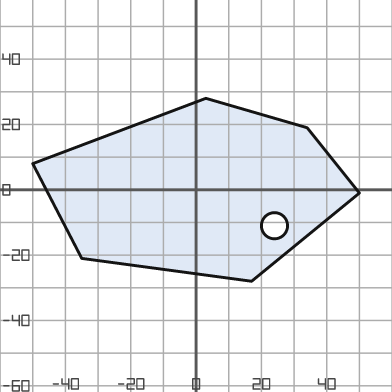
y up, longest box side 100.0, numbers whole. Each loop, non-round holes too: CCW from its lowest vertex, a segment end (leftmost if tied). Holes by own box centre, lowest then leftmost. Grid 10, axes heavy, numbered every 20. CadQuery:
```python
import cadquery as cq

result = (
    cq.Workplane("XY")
    .moveTo(17.0, -28.0)
    .lineTo(50.0, -1.0)
    .lineTo(34.0, 19.0)
    .lineTo(3.0, 28.0)
    .lineTo(-50.0, 8.0)
    .lineTo(-35.0, -21.0)
    .close()
    .moveTo(24.0, -11.0)
    .circle(4.0)
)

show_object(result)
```